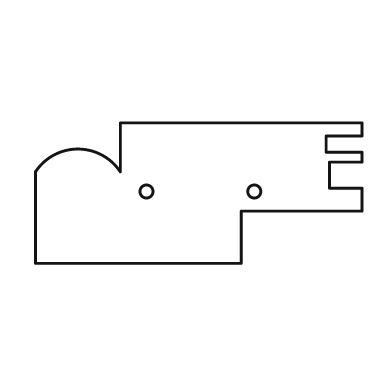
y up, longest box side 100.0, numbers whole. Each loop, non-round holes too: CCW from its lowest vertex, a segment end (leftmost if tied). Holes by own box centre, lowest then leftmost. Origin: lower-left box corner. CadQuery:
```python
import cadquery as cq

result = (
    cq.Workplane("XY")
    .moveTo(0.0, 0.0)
    .lineTo(63.0, 0.0)
    .lineTo(63.0, 16.0)
    .lineTo(100.0, 16.0)
    .lineTo(100.0, 23.0)
    .lineTo(90.0, 23.0)
    .lineTo(90.0, 31.0)
    .lineTo(100.0, 31.0)
    .lineTo(100.0, 34.0)
    .lineTo(89.0, 34.0)
    .lineTo(89.0, 39.0)
    .lineTo(100.0, 39.0)
    .lineTo(100.0, 43.0)
    .lineTo(26.0, 43.0)
    .lineTo(26.0, 28.0)
    .threePointArc((13.0, 35.0), (0.0, 28.0))
    .close()
    .moveTo(34.0, 22.0)
    .circle(2.0)
    .moveTo(67.0, 22.0)
    .circle(2.0)
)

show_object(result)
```